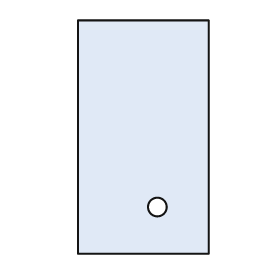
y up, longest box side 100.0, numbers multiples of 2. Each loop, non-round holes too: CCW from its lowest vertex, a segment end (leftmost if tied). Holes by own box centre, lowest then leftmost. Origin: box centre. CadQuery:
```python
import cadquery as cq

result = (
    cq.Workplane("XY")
    .moveTo(-28.0, -50.0)
    .lineTo(28.0, -50.0)
    .lineTo(28.0, 50.0)
    .lineTo(-28.0, 50.0)
    .close()
    .moveTo(6.0, -30.0)
    .circle(4.0)
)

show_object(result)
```